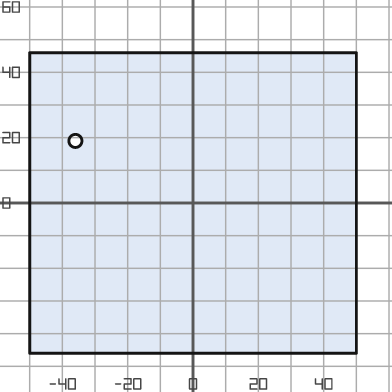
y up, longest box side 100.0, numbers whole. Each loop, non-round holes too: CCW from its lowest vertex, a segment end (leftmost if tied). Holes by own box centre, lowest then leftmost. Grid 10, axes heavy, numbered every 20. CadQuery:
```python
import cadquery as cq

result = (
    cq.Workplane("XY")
    .moveTo(-50.0, -46.0)
    .lineTo(50.0, -46.0)
    .lineTo(50.0, 46.0)
    .lineTo(-50.0, 46.0)
    .close()
    .moveTo(-36.0, 19.0)
    .circle(2.0)
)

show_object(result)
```